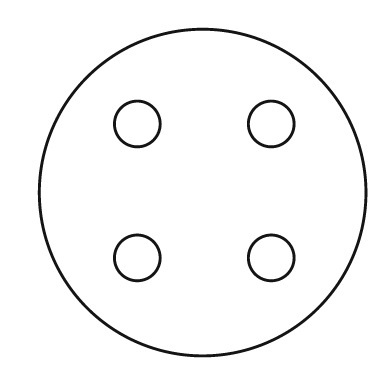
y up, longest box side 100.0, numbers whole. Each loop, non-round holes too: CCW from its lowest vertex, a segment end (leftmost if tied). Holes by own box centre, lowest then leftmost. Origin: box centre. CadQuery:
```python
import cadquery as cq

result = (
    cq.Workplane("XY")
    .moveTo(0.0, 0.0)
    .circle(50.0)
    .moveTo(-20.0, -20.0)
    .circle(7.0)
    .moveTo(21.0, -20.0)
    .circle(7.0)
    .moveTo(-20.0, 21.0)
    .circle(7.0)
    .moveTo(21.0, 21.0)
    .circle(7.0)
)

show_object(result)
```